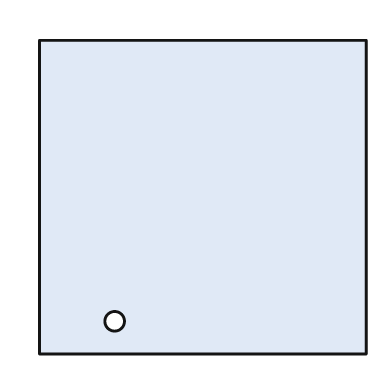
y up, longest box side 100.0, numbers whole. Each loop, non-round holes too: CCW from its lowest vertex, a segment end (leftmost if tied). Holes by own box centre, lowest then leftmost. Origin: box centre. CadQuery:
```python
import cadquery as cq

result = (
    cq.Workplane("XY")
    .moveTo(-50.0, -48.0)
    .lineTo(50.0, -48.0)
    .lineTo(50.0, 48.0)
    .lineTo(-50.0, 48.0)
    .close()
    .moveTo(-27.0, -38.0)
    .circle(3.0)
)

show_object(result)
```